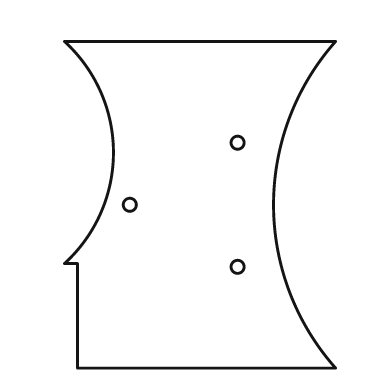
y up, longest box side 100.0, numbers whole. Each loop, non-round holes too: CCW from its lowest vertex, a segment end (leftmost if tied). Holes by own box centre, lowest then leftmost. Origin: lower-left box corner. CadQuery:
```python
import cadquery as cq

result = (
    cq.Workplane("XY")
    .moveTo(4.0, 0.0)
    .lineTo(83.0, 0.0)
    .threePointArc((64.0, 50.0), (83.0, 100.0))
    .lineTo(0.0, 100.0)
    .threePointArc((15.0, 66.0), (0.0, 32.0))
    .lineTo(4.0, 32.0)
    .close()
    .moveTo(53.0, 31.0)
    .circle(2.0)
    .moveTo(20.0, 50.0)
    .circle(2.0)
    .moveTo(53.0, 69.0)
    .circle(2.0)
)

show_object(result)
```